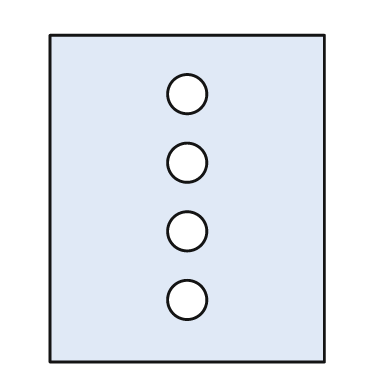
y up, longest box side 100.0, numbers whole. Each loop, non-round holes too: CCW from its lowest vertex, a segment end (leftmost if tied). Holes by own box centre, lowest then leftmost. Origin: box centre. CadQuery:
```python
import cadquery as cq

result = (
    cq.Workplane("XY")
    .moveTo(-42.0, -50.0)
    .lineTo(42.0, -50.0)
    .lineTo(42.0, 50.0)
    .lineTo(-42.0, 50.0)
    .close()
    .moveTo(0.0, -31.0)
    .circle(6.0)
    .moveTo(0.0, -10.0)
    .circle(6.0)
    .moveTo(0.0, 11.0)
    .circle(6.0)
    .moveTo(0.0, 32.0)
    .circle(6.0)
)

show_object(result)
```